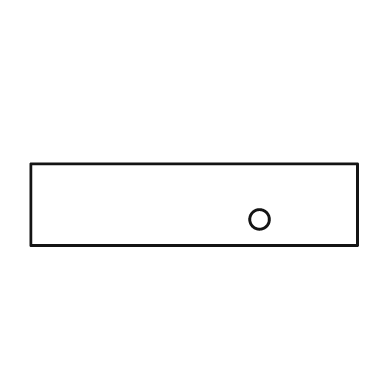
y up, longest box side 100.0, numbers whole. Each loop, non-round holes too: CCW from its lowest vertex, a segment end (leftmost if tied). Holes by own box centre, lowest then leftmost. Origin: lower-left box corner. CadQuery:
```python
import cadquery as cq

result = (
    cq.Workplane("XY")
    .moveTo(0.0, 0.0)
    .lineTo(100.0, 0.0)
    .lineTo(100.0, 25.0)
    .lineTo(0.0, 25.0)
    .close()
    .moveTo(70.0, 8.0)
    .circle(3.0)
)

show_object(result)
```